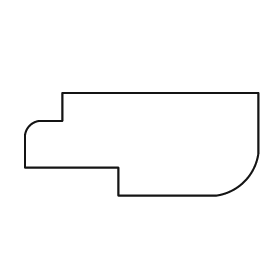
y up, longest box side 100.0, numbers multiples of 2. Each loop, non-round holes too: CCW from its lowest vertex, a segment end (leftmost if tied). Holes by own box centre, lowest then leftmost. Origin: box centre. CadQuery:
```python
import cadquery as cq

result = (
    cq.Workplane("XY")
    .moveTo(-10.0, -22.0)
    .lineTo(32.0, -22.0)
    .threePointArc((44.0, -16.0), (50.0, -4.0))
    .lineTo(50.0, 22.0)
    .lineTo(-34.0, 22.0)
    .lineTo(-34.0, 10.0)
    .lineTo(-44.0, 10.0)
    .threePointArc((-48.0, 8.0), (-50.0, 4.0))
    .lineTo(-50.0, -10.0)
    .lineTo(-10.0, -10.0)
    .close()
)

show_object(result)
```